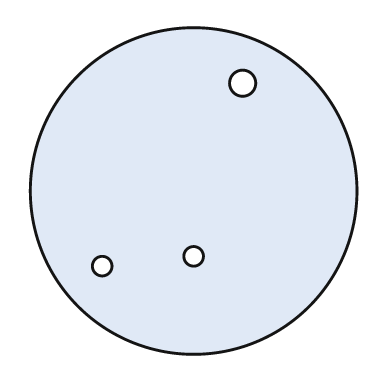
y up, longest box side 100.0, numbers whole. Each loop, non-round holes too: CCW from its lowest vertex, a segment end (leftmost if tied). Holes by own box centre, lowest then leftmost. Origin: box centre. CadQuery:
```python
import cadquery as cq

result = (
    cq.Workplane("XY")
    .moveTo(0.0, 0.0)
    .circle(50.0)
    .moveTo(-28.0, -23.0)
    .circle(3.0)
    .moveTo(0.0, -20.0)
    .circle(3.0)
    .moveTo(15.0, 33.0)
    .circle(4.0)
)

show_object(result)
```